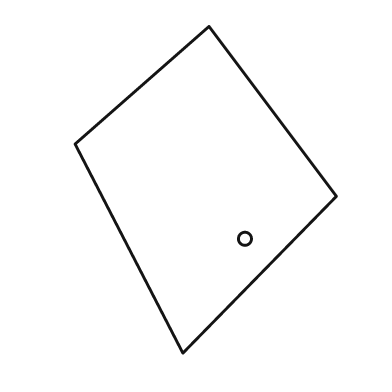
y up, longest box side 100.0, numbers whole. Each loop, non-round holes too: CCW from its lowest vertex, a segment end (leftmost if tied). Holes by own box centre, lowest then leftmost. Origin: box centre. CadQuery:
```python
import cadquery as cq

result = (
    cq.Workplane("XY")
    .moveTo(-7.0, -50.0)
    .lineTo(40.0, -2.0)
    .lineTo(1.0, 50.0)
    .lineTo(-40.0, 14.0)
    .close()
    .moveTo(12.0, -15.0)
    .circle(2.0)
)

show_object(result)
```